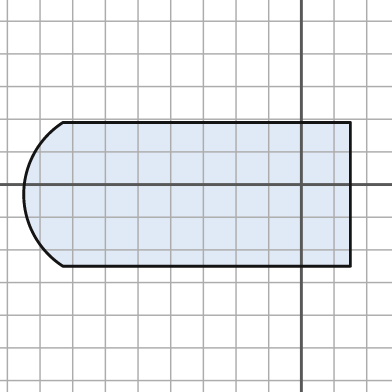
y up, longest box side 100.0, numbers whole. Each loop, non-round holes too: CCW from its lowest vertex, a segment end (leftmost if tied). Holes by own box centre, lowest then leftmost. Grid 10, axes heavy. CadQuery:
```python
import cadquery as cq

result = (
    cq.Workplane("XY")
    .moveTo(-73.0, -25.0)
    .lineTo(15.0, -25.0)
    .lineTo(15.0, 19.0)
    .lineTo(-73.0, 19.0)
    .threePointArc((-85.0, -3.0), (-73.0, -25.0))
    .close()
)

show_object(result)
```